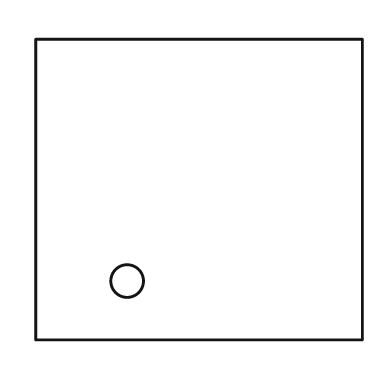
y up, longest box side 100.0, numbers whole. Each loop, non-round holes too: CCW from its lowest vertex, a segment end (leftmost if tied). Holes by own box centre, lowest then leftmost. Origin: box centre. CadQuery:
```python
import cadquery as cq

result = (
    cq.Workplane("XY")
    .moveTo(-50.0, -46.0)
    .lineTo(50.0, -46.0)
    .lineTo(50.0, 46.0)
    .lineTo(-50.0, 46.0)
    .close()
    .moveTo(-22.0, -28.0)
    .circle(5.0)
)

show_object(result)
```